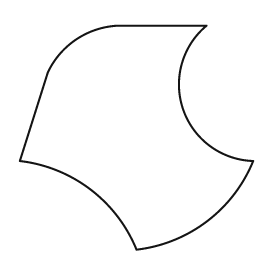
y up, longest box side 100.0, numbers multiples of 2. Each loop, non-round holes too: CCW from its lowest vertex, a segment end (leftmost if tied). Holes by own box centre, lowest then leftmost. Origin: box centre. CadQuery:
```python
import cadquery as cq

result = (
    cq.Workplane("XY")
    .moveTo(0.0, -48.0)
    .threePointArc((30.0, -36.0), (50.0, -10.0))
    .threePointArc((20.0, 12.0), (30.0, 48.0))
    .lineTo(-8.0, 48.0)
    .threePointArc((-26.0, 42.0), (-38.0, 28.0))
    .lineTo(-50.0, -10.0)
    .threePointArc((-20.0, -22.0), (0.0, -48.0))
    .close()
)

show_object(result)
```